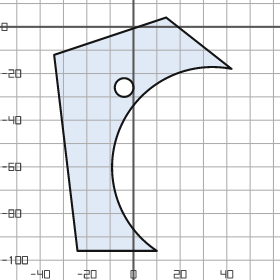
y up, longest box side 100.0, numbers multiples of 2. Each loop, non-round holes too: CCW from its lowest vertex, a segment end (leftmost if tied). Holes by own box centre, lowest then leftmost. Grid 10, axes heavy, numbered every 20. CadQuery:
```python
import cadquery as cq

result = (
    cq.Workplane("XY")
    .moveTo(-24.0, -96.0)
    .lineTo(10.0, -96.0)
    .threePointArc((-6.0, -44.0), (42.0, -18.0))
    .lineTo(14.0, 4.0)
    .lineTo(-34.0, -12.0)
    .close()
    .moveTo(-4.0, -26.0)
    .circle(4.0)
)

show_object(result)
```